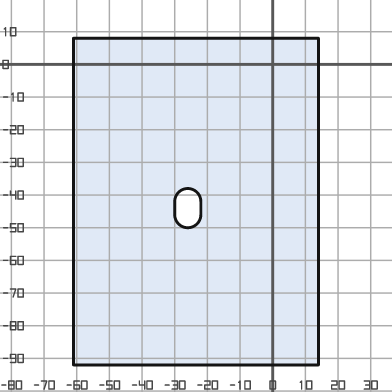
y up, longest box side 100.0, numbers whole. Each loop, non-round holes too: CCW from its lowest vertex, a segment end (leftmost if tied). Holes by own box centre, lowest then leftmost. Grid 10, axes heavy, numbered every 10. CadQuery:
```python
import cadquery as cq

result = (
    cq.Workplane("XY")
    .moveTo(-61.0, -92.0)
    .lineTo(14.0, -92.0)
    .lineTo(14.0, 8.0)
    .lineTo(-61.0, 8.0)
    .close()
    .moveTo(-30.0, -46.0)
    .threePointArc((-26.0, -50.0), (-22.0, -46.0))
    .lineTo(-22.0, -42.0)
    .threePointArc((-26.0, -38.0), (-30.0, -42.0))
    .close()
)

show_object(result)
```